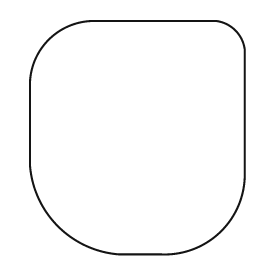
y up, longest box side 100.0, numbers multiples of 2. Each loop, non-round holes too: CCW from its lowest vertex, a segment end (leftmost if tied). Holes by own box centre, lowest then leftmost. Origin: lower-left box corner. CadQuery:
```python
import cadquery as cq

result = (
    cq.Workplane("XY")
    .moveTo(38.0, 0.0)
    .lineTo(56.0, 0.0)
    .threePointArc((82.0, 10.0), (92.0, 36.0))
    .lineTo(92.0, 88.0)
    .threePointArc((88.0, 96.0), (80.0, 100.0))
    .lineTo(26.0, 100.0)
    .threePointArc((8.0, 92.0), (0.0, 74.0))
    .lineTo(0.0, 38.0)
    .threePointArc((12.0, 12.0), (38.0, 0.0))
    .close()
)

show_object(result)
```